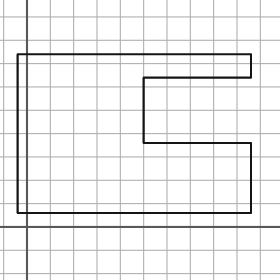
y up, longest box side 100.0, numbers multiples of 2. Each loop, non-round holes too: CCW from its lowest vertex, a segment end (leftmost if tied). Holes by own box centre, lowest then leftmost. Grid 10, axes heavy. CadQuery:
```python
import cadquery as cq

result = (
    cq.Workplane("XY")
    .moveTo(-4.0, 6.0)
    .lineTo(96.0, 6.0)
    .lineTo(96.0, 36.0)
    .lineTo(50.0, 36.0)
    .lineTo(50.0, 64.0)
    .lineTo(96.0, 64.0)
    .lineTo(96.0, 74.0)
    .lineTo(-4.0, 74.0)
    .close()
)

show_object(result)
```